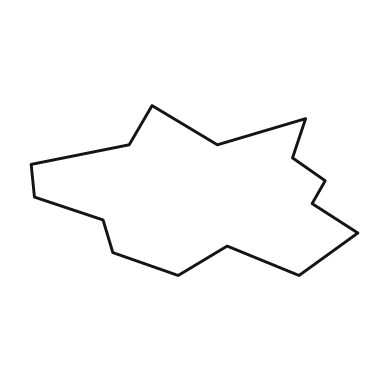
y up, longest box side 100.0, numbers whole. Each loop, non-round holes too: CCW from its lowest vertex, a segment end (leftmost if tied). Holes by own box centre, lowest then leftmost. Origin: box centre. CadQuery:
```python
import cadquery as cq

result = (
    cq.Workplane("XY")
    .moveTo(-5.0, -26.0)
    .lineTo(10.0, -17.0)
    .lineTo(32.0, -26.0)
    .lineTo(50.0, -13.0)
    .lineTo(36.0, -4.0)
    .lineTo(40.0, 3.0)
    .lineTo(30.0, 10.0)
    .lineTo(34.0, 22.0)
    .lineTo(7.0, 14.0)
    .lineTo(-13.0, 26.0)
    .lineTo(-20.0, 14.0)
    .lineTo(-50.0, 8.0)
    .lineTo(-49.0, -2.0)
    .lineTo(-28.0, -9.0)
    .lineTo(-25.0, -19.0)
    .close()
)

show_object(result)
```